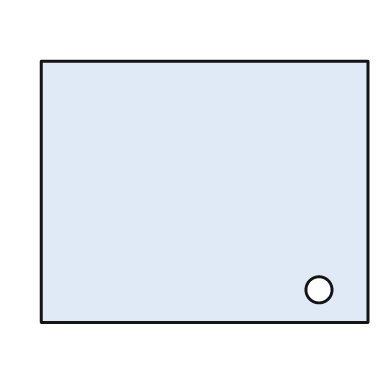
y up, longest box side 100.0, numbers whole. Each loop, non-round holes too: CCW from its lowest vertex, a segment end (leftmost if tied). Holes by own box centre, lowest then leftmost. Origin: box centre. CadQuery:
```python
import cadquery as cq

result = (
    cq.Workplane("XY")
    .moveTo(-50.0, -40.0)
    .lineTo(50.0, -40.0)
    .lineTo(50.0, 40.0)
    .lineTo(-50.0, 40.0)
    .close()
    .moveTo(35.0, -30.0)
    .circle(4.0)
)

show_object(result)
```